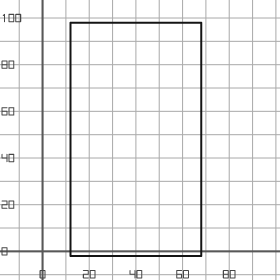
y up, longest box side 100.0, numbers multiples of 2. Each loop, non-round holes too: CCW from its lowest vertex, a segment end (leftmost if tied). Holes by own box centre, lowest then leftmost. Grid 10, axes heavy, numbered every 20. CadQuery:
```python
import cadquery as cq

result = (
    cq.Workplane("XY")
    .moveTo(12.0, -2.0)
    .lineTo(68.0, -2.0)
    .lineTo(68.0, 98.0)
    .lineTo(12.0, 98.0)
    .close()
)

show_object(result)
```